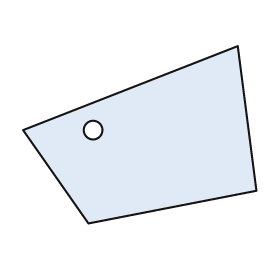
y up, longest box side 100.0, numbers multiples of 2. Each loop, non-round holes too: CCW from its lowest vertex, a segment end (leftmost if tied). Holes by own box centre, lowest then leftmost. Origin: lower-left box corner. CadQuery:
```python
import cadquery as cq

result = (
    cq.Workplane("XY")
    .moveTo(28.0, 0.0)
    .lineTo(100.0, 14.0)
    .lineTo(92.0, 76.0)
    .lineTo(0.0, 40.0)
    .close()
    .moveTo(30.0, 40.0)
    .circle(4.0)
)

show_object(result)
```